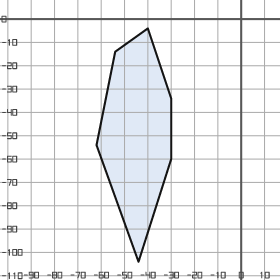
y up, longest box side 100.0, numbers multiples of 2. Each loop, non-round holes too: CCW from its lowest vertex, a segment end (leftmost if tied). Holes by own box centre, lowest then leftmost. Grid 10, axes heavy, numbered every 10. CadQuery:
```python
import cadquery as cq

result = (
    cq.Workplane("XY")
    .moveTo(-44.0, -104.0)
    .lineTo(-30.0, -60.0)
    .lineTo(-30.0, -34.0)
    .lineTo(-40.0, -4.0)
    .lineTo(-54.0, -14.0)
    .lineTo(-62.0, -54.0)
    .close()
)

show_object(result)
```